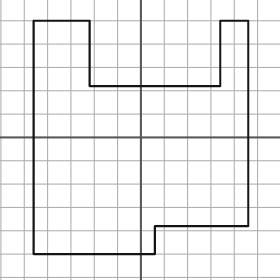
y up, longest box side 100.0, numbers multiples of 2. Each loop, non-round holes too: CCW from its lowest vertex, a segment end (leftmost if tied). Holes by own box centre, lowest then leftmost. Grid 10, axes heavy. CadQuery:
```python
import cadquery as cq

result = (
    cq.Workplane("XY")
    .moveTo(-46.0, -50.0)
    .lineTo(6.0, -50.0)
    .lineTo(6.0, -38.0)
    .lineTo(46.0, -38.0)
    .lineTo(46.0, 50.0)
    .lineTo(34.0, 50.0)
    .lineTo(34.0, 22.0)
    .lineTo(-22.0, 22.0)
    .lineTo(-22.0, 50.0)
    .lineTo(-46.0, 50.0)
    .close()
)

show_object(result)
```